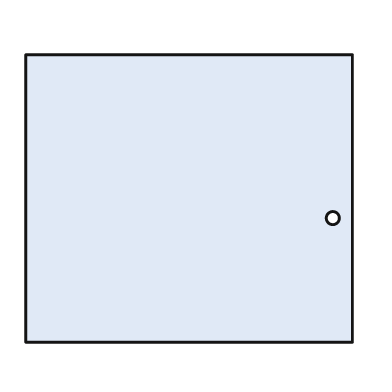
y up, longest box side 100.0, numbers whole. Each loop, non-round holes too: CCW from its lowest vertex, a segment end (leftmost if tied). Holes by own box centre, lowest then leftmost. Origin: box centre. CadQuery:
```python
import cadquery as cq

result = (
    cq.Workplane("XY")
    .moveTo(-50.0, -44.0)
    .lineTo(50.0, -44.0)
    .lineTo(50.0, 44.0)
    .lineTo(-50.0, 44.0)
    .close()
    .moveTo(44.0, -6.0)
    .circle(2.0)
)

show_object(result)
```